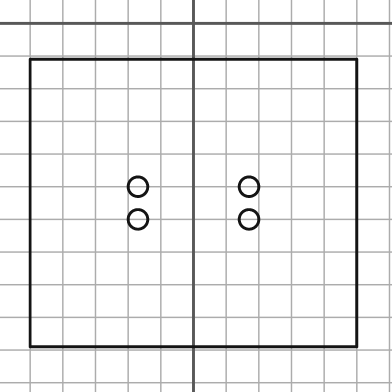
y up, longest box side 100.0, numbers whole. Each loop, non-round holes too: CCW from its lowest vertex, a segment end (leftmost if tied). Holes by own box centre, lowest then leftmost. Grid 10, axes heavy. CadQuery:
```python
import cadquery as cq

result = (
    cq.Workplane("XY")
    .moveTo(-50.0, -99.0)
    .lineTo(50.0, -99.0)
    .lineTo(50.0, -11.0)
    .lineTo(-50.0, -11.0)
    .close()
    .moveTo(-17.0, -60.0)
    .circle(3.0)
    .moveTo(17.0, -60.0)
    .circle(3.0)
    .moveTo(-17.0, -50.0)
    .circle(3.0)
    .moveTo(17.0, -50.0)
    .circle(3.0)
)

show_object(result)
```